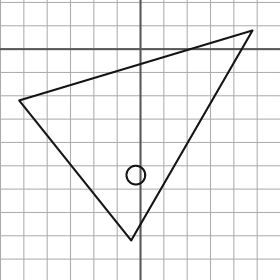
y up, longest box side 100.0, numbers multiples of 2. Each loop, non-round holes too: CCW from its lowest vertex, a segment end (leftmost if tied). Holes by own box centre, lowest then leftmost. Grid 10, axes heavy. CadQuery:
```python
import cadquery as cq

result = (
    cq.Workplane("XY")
    .moveTo(-4.0, -82.0)
    .lineTo(48.0, 8.0)
    .lineTo(-52.0, -22.0)
    .close()
    .moveTo(-2.0, -54.0)
    .circle(4.0)
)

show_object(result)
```